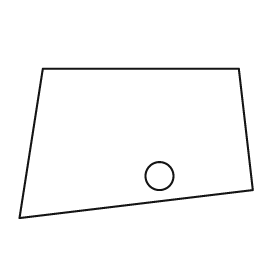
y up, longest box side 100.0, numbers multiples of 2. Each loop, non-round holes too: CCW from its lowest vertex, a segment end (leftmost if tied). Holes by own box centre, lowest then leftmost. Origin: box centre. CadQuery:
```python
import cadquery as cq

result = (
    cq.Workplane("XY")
    .moveTo(-50.0, -32.0)
    .lineTo(50.0, -20.0)
    .lineTo(44.0, 32.0)
    .lineTo(-40.0, 32.0)
    .close()
    .moveTo(10.0, -14.0)
    .circle(6.0)
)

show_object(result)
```